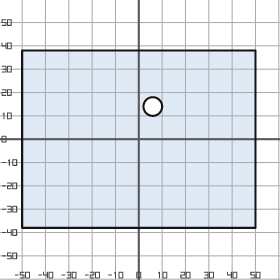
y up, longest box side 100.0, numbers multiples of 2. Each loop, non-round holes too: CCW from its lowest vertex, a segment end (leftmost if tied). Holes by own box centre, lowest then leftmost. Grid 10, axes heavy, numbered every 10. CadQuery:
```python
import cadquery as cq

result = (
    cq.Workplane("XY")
    .moveTo(-50.0, -38.0)
    .lineTo(50.0, -38.0)
    .lineTo(50.0, 38.0)
    .lineTo(-50.0, 38.0)
    .close()
    .moveTo(6.0, 14.0)
    .circle(4.0)
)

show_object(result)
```